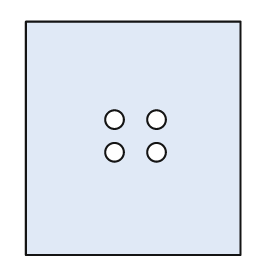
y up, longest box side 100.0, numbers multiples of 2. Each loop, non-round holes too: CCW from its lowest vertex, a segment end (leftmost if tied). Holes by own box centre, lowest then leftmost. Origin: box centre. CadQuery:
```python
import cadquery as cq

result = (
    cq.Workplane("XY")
    .moveTo(-46.0, -50.0)
    .lineTo(46.0, -50.0)
    .lineTo(46.0, 50.0)
    .lineTo(-46.0, 50.0)
    .close()
    .moveTo(-8.0, -6.0)
    .circle(4.0)
    .moveTo(10.0, -6.0)
    .circle(4.0)
    .moveTo(-8.0, 8.0)
    .circle(4.0)
    .moveTo(10.0, 8.0)
    .circle(4.0)
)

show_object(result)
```